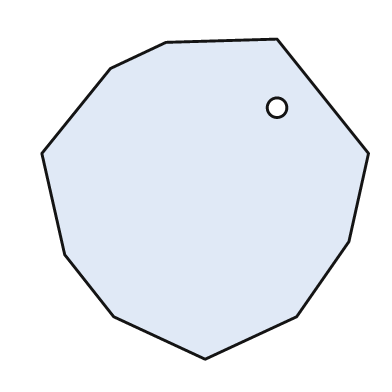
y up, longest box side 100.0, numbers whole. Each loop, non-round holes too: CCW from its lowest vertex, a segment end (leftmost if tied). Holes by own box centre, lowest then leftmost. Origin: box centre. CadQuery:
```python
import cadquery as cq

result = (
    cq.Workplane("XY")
    .moveTo(0.0, -49.0)
    .lineTo(28.0, -36.0)
    .lineTo(44.0, -13.0)
    .lineTo(50.0, 14.0)
    .lineTo(22.0, 49.0)
    .lineTo(-12.0, 48.0)
    .lineTo(-29.0, 40.0)
    .lineTo(-50.0, 14.0)
    .lineTo(-43.0, -17.0)
    .lineTo(-28.0, -36.0)
    .close()
    .moveTo(22.0, 28.0)
    .circle(3.0)
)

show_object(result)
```